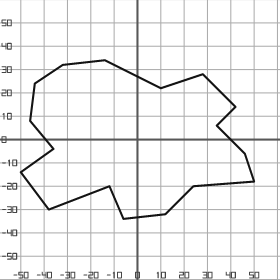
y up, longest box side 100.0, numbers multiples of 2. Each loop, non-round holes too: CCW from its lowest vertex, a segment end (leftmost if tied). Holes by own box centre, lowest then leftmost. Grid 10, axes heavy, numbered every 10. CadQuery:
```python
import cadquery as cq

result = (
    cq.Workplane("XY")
    .moveTo(-6.0, -34.0)
    .lineTo(12.0, -32.0)
    .lineTo(24.0, -20.0)
    .lineTo(50.0, -18.0)
    .lineTo(46.0, -6.0)
    .lineTo(34.0, 6.0)
    .lineTo(42.0, 14.0)
    .lineTo(28.0, 28.0)
    .lineTo(10.0, 22.0)
    .lineTo(-14.0, 34.0)
    .lineTo(-32.0, 32.0)
    .lineTo(-44.0, 24.0)
    .lineTo(-46.0, 8.0)
    .lineTo(-36.0, -4.0)
    .lineTo(-50.0, -14.0)
    .lineTo(-38.0, -30.0)
    .lineTo(-12.0, -20.0)
    .close()
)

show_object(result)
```